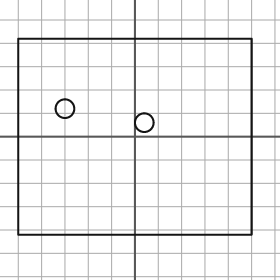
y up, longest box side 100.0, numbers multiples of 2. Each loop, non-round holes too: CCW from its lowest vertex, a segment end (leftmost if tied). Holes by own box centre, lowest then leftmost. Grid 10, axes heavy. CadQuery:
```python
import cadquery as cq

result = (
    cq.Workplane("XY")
    .moveTo(-50.0, -42.0)
    .lineTo(50.0, -42.0)
    .lineTo(50.0, 42.0)
    .lineTo(-50.0, 42.0)
    .close()
    .moveTo(4.0, 6.0)
    .circle(4.0)
    .moveTo(-30.0, 12.0)
    .circle(4.0)
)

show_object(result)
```